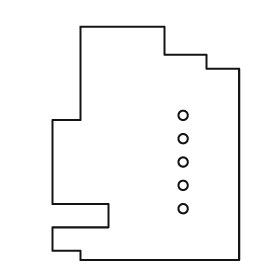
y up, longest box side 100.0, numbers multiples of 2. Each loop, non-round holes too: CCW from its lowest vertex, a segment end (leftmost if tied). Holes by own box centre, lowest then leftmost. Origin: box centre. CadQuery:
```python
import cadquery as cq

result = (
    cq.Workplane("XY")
    .moveTo(-28.0, -50.0)
    .lineTo(40.0, -50.0)
    .lineTo(40.0, 32.0)
    .lineTo(26.0, 32.0)
    .lineTo(26.0, 38.0)
    .lineTo(8.0, 38.0)
    .lineTo(8.0, 50.0)
    .lineTo(-28.0, 50.0)
    .lineTo(-28.0, 10.0)
    .lineTo(-40.0, 10.0)
    .lineTo(-40.0, -26.0)
    .lineTo(-16.0, -26.0)
    .lineTo(-16.0, -36.0)
    .lineTo(-40.0, -36.0)
    .lineTo(-40.0, -46.0)
    .lineTo(-28.0, -46.0)
    .close()
    .moveTo(16.0, -28.0)
    .circle(2.0)
    .moveTo(16.0, -18.0)
    .circle(2.0)
    .moveTo(16.0, -8.0)
    .circle(2.0)
    .moveTo(16.0, 2.0)
    .circle(2.0)
    .moveTo(16.0, 12.0)
    .circle(2.0)
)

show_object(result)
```